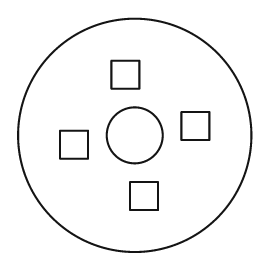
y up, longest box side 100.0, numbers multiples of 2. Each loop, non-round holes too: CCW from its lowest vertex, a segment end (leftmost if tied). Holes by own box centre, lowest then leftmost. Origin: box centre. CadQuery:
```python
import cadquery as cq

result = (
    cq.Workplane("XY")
    .moveTo(0.0, 0.0)
    .circle(50.0)
    .moveTo(-2.0, -32.0)
    .lineTo(10.0, -32.0)
    .lineTo(10.0, -20.0)
    .lineTo(-2.0, -20.0)
    .close()
    .moveTo(-32.0, -10.0)
    .lineTo(-20.0, -10.0)
    .lineTo(-20.0, 2.0)
    .lineTo(-32.0, 2.0)
    .close()
    .moveTo(0.0, 0.0)
    .circle(12.0)
    .moveTo(20.0, -2.0)
    .lineTo(32.0, -2.0)
    .lineTo(32.0, 10.0)
    .lineTo(20.0, 10.0)
    .close()
    .moveTo(-10.0, 20.0)
    .lineTo(2.0, 20.0)
    .lineTo(2.0, 32.0)
    .lineTo(-10.0, 32.0)
    .close()
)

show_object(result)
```